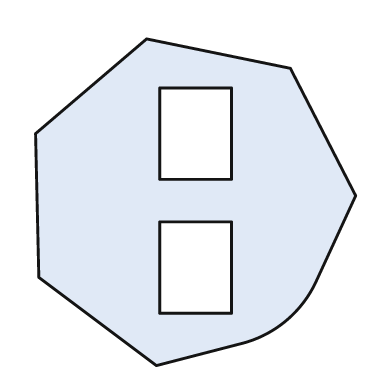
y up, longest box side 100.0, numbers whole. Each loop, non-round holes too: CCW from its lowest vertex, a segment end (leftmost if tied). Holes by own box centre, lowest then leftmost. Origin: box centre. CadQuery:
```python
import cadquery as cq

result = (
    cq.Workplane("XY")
    .moveTo(-12.0, -50.0)
    .lineTo(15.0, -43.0)
    .threePointArc((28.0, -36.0), (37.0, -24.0))
    .lineTo(49.0, 2.0)
    .lineTo(29.0, 41.0)
    .lineTo(-15.0, 50.0)
    .lineTo(-49.0, 21.0)
    .lineTo(-48.0, -23.0)
    .close()
    .moveTo(-11.0, -34.0)
    .lineTo(11.0, -34.0)
    .lineTo(11.0, -6.0)
    .lineTo(-11.0, -6.0)
    .close()
    .moveTo(-11.0, 7.0)
    .lineTo(11.0, 7.0)
    .lineTo(11.0, 35.0)
    .lineTo(-11.0, 35.0)
    .close()
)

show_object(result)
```